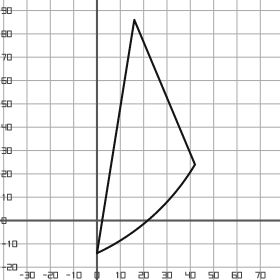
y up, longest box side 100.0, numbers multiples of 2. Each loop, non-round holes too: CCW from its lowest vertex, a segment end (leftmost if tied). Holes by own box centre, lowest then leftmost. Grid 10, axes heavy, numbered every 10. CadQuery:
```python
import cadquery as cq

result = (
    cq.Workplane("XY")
    .moveTo(0.0, -14.0)
    .threePointArc((24.0, 2.0), (42.0, 24.0))
    .lineTo(16.0, 86.0)
    .close()
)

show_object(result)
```